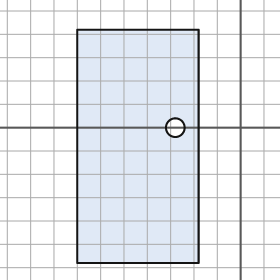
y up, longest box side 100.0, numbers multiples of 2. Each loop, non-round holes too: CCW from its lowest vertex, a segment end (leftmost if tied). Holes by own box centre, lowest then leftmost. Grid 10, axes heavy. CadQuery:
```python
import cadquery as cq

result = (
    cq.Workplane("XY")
    .moveTo(-70.0, -58.0)
    .lineTo(-18.0, -58.0)
    .lineTo(-18.0, 42.0)
    .lineTo(-70.0, 42.0)
    .close()
    .moveTo(-28.0, 0.0)
    .circle(4.0)
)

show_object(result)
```